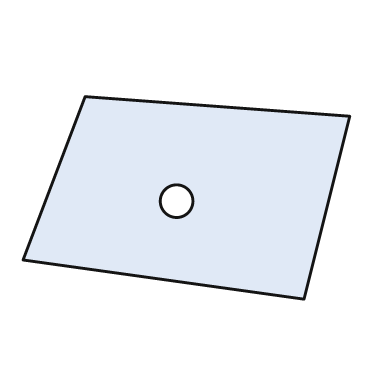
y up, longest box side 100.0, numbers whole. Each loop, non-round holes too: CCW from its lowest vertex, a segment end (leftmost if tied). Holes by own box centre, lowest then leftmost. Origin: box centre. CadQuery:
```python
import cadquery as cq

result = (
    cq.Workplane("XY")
    .moveTo(36.0, -31.0)
    .lineTo(50.0, 25.0)
    .lineTo(-31.0, 31.0)
    .lineTo(-50.0, -19.0)
    .close()
    .moveTo(-3.0, -1.0)
    .circle(5.0)
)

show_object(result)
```